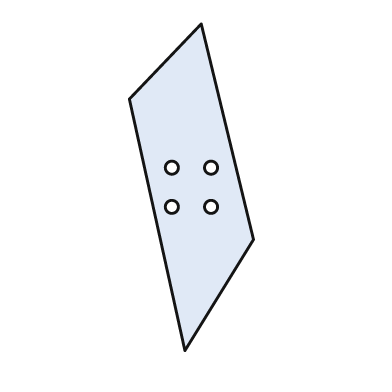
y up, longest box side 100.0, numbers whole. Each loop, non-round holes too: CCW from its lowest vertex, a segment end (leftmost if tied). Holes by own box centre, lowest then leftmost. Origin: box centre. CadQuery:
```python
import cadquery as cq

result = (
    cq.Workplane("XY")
    .moveTo(-2.0, -50.0)
    .lineTo(19.0, -16.0)
    .lineTo(3.0, 50.0)
    .lineTo(-19.0, 27.0)
    .close()
    .moveTo(-6.0, -6.0)
    .circle(2.0)
    .moveTo(6.0, -6.0)
    .circle(2.0)
    .moveTo(-6.0, 6.0)
    .circle(2.0)
    .moveTo(6.0, 6.0)
    .circle(2.0)
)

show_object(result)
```